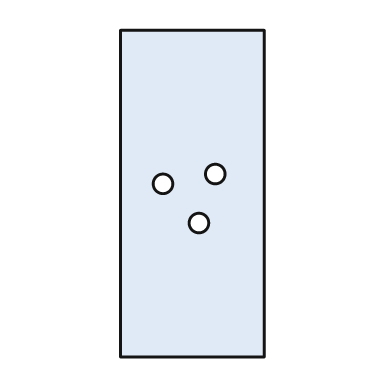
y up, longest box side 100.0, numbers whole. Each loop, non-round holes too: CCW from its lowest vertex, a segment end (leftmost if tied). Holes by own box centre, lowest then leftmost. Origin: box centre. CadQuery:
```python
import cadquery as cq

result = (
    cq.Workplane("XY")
    .moveTo(-22.0, -50.0)
    .lineTo(22.0, -50.0)
    .lineTo(22.0, 50.0)
    .lineTo(-22.0, 50.0)
    .close()
    .moveTo(2.0, -9.0)
    .circle(3.0)
    .moveTo(-9.0, 3.0)
    .circle(3.0)
    .moveTo(7.0, 6.0)
    .circle(3.0)
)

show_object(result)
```